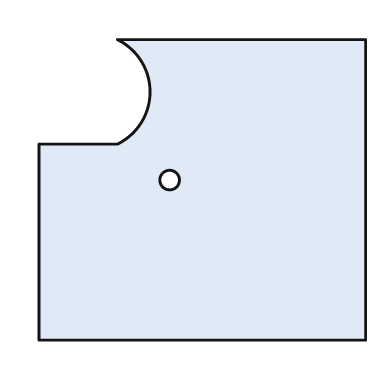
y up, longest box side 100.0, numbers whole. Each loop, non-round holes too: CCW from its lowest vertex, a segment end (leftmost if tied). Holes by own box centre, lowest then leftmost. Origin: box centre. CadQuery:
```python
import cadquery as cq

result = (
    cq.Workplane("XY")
    .moveTo(-50.0, -46.0)
    .lineTo(50.0, -46.0)
    .lineTo(50.0, 46.0)
    .lineTo(-26.0, 46.0)
    .threePointArc((-16.0, 30.0), (-26.0, 14.0))
    .lineTo(-50.0, 14.0)
    .close()
    .moveTo(-10.0, 3.0)
    .circle(3.0)
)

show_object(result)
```